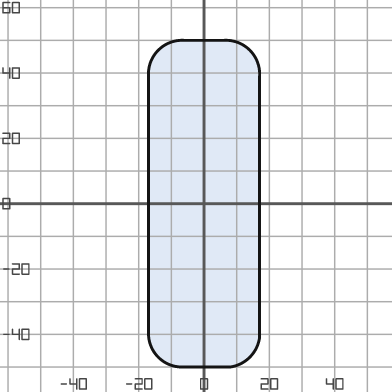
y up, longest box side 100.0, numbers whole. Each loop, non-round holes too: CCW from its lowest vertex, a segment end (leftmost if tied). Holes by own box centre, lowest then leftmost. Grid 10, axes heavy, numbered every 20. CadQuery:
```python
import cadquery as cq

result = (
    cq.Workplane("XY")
    .moveTo(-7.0, -50.0)
    .lineTo(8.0, -50.0)
    .threePointArc((14.0, -47.0), (17.0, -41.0))
    .lineTo(17.0, 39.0)
    .threePointArc((14.0, 47.0), (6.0, 50.0))
    .lineTo(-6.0, 50.0)
    .threePointArc((-14.0, 47.0), (-17.0, 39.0))
    .lineTo(-17.0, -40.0)
    .threePointArc((-14.0, -47.0), (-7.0, -50.0))
    .close()
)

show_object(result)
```